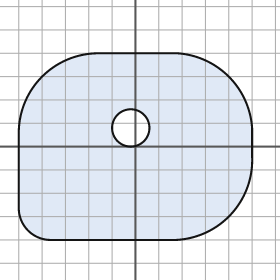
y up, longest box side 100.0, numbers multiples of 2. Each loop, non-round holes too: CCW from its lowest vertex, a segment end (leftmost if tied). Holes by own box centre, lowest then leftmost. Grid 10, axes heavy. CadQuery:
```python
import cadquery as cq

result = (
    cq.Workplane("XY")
    .moveTo(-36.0, -40.0)
    .lineTo(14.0, -40.0)
    .threePointArc((40.0, -30.0), (50.0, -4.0))
    .lineTo(50.0, 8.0)
    .threePointArc((40.0, 30.0), (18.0, 40.0))
    .lineTo(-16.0, 40.0)
    .threePointArc((-40.0, 30.0), (-50.0, 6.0))
    .lineTo(-50.0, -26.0)
    .threePointArc((-46.0, -36.0), (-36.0, -40.0))
    .close()
    .moveTo(-2.0, 8.0)
    .circle(8.0)
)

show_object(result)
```